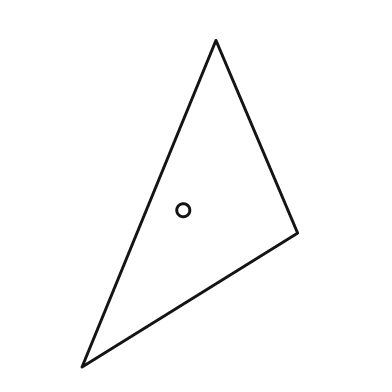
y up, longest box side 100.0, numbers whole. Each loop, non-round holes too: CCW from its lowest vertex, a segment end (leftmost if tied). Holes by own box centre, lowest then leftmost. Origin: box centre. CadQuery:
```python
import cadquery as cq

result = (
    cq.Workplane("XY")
    .moveTo(-33.0, -50.0)
    .lineTo(33.0, -9.0)
    .lineTo(8.0, 50.0)
    .close()
    .moveTo(-2.0, -2.0)
    .circle(2.0)
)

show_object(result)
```